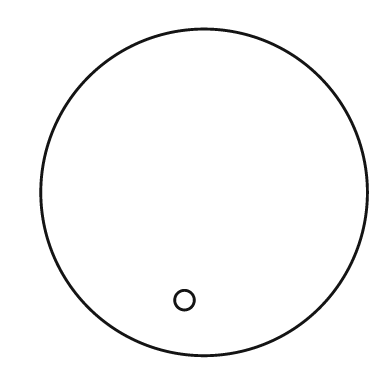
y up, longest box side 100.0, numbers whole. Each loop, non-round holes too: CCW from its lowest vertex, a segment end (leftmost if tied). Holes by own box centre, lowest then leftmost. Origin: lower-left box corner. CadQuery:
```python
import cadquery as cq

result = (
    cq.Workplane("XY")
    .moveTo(50.0, 50.0)
    .circle(50.0)
    .moveTo(44.0, 17.0)
    .circle(3.0)
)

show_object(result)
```